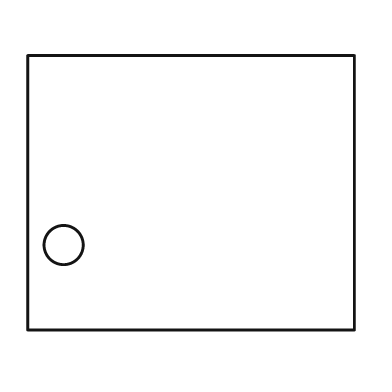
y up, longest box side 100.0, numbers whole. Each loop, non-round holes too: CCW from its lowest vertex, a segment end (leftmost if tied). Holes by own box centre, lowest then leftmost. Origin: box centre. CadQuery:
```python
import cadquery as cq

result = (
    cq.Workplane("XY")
    .moveTo(-50.0, -42.0)
    .lineTo(50.0, -42.0)
    .lineTo(50.0, 42.0)
    .lineTo(-50.0, 42.0)
    .close()
    .moveTo(-39.0, -16.0)
    .circle(6.0)
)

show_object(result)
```